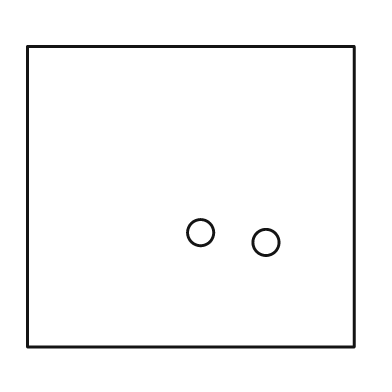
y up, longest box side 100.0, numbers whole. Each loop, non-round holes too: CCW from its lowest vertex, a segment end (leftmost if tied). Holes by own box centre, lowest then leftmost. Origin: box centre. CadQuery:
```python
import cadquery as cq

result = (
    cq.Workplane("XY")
    .moveTo(-50.0, -46.0)
    .lineTo(50.0, -46.0)
    .lineTo(50.0, 46.0)
    .lineTo(-50.0, 46.0)
    .close()
    .moveTo(23.0, -14.0)
    .circle(4.0)
    .moveTo(3.0, -11.0)
    .circle(4.0)
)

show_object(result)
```